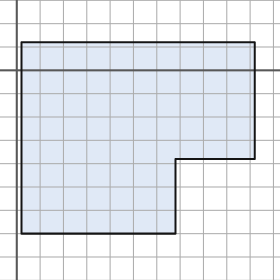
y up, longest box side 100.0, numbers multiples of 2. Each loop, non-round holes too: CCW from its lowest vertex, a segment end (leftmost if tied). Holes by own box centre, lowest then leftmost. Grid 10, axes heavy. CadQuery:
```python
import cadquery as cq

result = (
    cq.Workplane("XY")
    .moveTo(2.0, -70.0)
    .lineTo(68.0, -70.0)
    .lineTo(68.0, -38.0)
    .lineTo(102.0, -38.0)
    .lineTo(102.0, 12.0)
    .lineTo(2.0, 12.0)
    .close()
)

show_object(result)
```